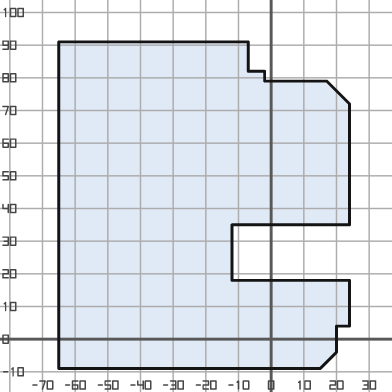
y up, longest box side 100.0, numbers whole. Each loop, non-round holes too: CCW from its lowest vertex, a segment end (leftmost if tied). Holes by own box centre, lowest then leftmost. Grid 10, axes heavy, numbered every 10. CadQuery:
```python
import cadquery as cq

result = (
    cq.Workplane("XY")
    .moveTo(-65.0, -9.0)
    .lineTo(15.0, -9.0)
    .lineTo(20.0, -4.0)
    .lineTo(20.0, 4.0)
    .lineTo(24.0, 4.0)
    .lineTo(24.0, 18.0)
    .lineTo(-12.0, 18.0)
    .lineTo(-12.0, 35.0)
    .lineTo(24.0, 35.0)
    .lineTo(24.0, 72.0)
    .lineTo(17.0, 79.0)
    .lineTo(-2.0, 79.0)
    .lineTo(-2.0, 82.0)
    .lineTo(-7.0, 82.0)
    .lineTo(-7.0, 91.0)
    .lineTo(-65.0, 91.0)
    .close()
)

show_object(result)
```